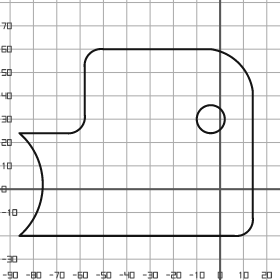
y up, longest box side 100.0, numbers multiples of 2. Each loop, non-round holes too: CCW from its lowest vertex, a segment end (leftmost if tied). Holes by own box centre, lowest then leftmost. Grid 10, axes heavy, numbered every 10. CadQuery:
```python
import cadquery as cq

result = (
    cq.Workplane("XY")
    .moveTo(-86.0, -20.0)
    .lineTo(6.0, -20.0)
    .threePointArc((12.0, -18.0), (14.0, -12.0))
    .lineTo(14.0, 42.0)
    .threePointArc((8.0, 54.0), (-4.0, 60.0))
    .lineTo(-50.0, 60.0)
    .threePointArc((-56.0, 58.0), (-58.0, 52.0))
    .lineTo(-58.0, 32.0)
    .threePointArc((-60.0, 26.0), (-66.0, 24.0))
    .lineTo(-86.0, 24.0)
    .threePointArc((-76.0, 2.0), (-86.0, -20.0))
    .close()
    .moveTo(-4.0, 30.0)
    .circle(6.0)
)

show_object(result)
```